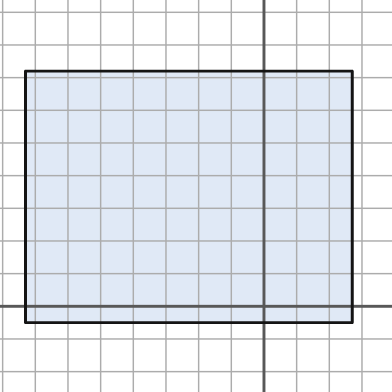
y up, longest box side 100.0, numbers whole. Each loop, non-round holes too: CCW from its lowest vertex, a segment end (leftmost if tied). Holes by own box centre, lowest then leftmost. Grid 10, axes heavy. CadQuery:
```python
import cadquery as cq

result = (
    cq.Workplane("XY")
    .moveTo(-73.0, -5.0)
    .lineTo(27.0, -5.0)
    .lineTo(27.0, 72.0)
    .lineTo(-73.0, 72.0)
    .close()
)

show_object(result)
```